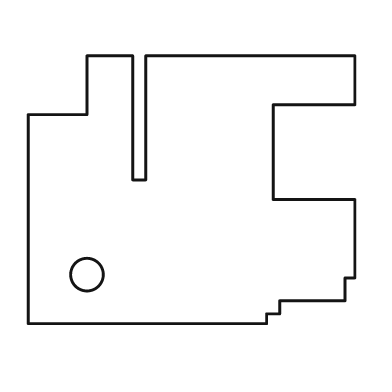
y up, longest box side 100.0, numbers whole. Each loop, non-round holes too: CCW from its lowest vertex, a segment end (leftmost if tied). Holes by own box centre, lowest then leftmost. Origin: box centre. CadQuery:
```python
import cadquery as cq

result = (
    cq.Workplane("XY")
    .moveTo(-50.0, -41.0)
    .lineTo(23.0, -41.0)
    .lineTo(23.0, -38.0)
    .lineTo(27.0, -38.0)
    .lineTo(27.0, -34.0)
    .lineTo(47.0, -34.0)
    .lineTo(47.0, -27.0)
    .lineTo(50.0, -27.0)
    .lineTo(50.0, -3.0)
    .lineTo(25.0, -3.0)
    .lineTo(25.0, 26.0)
    .lineTo(50.0, 26.0)
    .lineTo(50.0, 41.0)
    .lineTo(-14.0, 41.0)
    .lineTo(-14.0, 3.0)
    .lineTo(-18.0, 3.0)
    .lineTo(-18.0, 41.0)
    .lineTo(-32.0, 41.0)
    .lineTo(-32.0, 23.0)
    .lineTo(-50.0, 23.0)
    .close()
    .moveTo(-32.0, -26.0)
    .circle(5.0)
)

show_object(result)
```